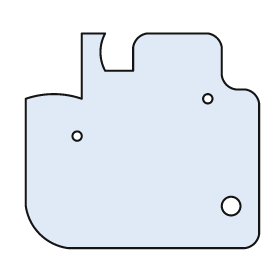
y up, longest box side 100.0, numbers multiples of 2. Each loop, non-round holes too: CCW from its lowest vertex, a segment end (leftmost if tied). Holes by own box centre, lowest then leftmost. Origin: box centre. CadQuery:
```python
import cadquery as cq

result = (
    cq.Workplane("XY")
    .moveTo(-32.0, -46.0)
    .lineTo(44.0, -46.0)
    .threePointArc((48.0, -44.0), (50.0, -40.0))
    .lineTo(50.0, 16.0)
    .threePointArc((48.0, 20.0), (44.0, 22.0))
    .lineTo(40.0, 22.0)
    .threePointArc((36.0, 24.0), (34.0, 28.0))
    .lineTo(34.0, 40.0)
    .threePointArc((32.0, 44.0), (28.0, 46.0))
    .lineTo(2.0, 46.0)
    .threePointArc((-2.0, 44.0), (-4.0, 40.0))
    .lineTo(-4.0, 30.0)
    .lineTo(-16.0, 30.0)
    .threePointArc((-18.0, 38.0), (-16.0, 46.0))
    .lineTo(-26.0, 46.0)
    .lineTo(-26.0, 18.0)
    .threePointArc((-38.0, 20.0), (-50.0, 18.0))
    .lineTo(-50.0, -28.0)
    .threePointArc((-44.0, -40.0), (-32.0, -46.0))
    .close()
    .moveTo(38.0, -28.0)
    .circle(4.0)
    .moveTo(-28.0, 2.0)
    .circle(2.0)
    .moveTo(28.0, 18.0)
    .circle(2.0)
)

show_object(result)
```